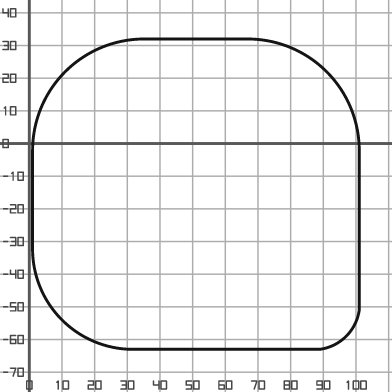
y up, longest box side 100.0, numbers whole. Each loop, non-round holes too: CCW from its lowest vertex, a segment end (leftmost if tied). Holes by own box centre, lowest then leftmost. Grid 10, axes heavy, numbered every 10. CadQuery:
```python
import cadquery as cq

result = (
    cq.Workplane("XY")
    .moveTo(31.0, -63.0)
    .lineTo(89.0, -63.0)
    .threePointArc((97.0, -59.0), (101.0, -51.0))
    .lineTo(101.0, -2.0)
    .threePointArc((91.0, 22.0), (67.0, 32.0))
    .lineTo(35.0, 32.0)
    .threePointArc((11.0, 22.0), (1.0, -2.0))
    .lineTo(1.0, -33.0)
    .threePointArc((10.0, -54.0), (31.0, -63.0))
    .close()
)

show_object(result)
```